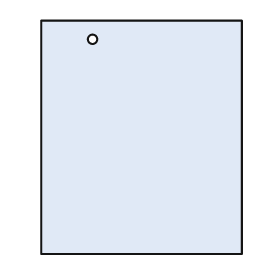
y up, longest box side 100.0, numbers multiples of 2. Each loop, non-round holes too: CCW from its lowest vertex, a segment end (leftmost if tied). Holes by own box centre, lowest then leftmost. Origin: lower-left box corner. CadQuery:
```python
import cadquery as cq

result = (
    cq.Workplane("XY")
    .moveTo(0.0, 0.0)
    .lineTo(86.0, 0.0)
    .lineTo(86.0, 100.0)
    .lineTo(0.0, 100.0)
    .close()
    .moveTo(22.0, 92.0)
    .circle(2.0)
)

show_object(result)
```